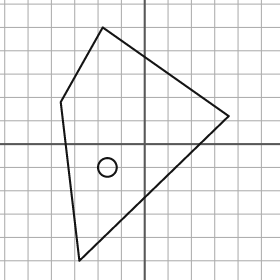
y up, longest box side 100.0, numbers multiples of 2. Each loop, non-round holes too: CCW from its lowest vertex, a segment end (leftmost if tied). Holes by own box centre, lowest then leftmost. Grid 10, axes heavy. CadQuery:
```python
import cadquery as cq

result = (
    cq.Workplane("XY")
    .moveTo(-28.0, -50.0)
    .lineTo(36.0, 12.0)
    .lineTo(-18.0, 50.0)
    .lineTo(-36.0, 18.0)
    .close()
    .moveTo(-16.0, -10.0)
    .circle(4.0)
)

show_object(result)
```